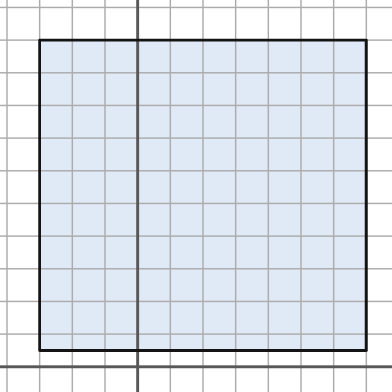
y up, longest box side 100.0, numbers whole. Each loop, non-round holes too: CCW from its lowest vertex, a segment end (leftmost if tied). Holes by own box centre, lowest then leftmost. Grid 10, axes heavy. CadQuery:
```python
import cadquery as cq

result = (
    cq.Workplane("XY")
    .moveTo(-30.0, 5.0)
    .lineTo(70.0, 5.0)
    .lineTo(70.0, 100.0)
    .lineTo(-30.0, 100.0)
    .close()
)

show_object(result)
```